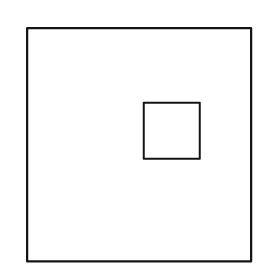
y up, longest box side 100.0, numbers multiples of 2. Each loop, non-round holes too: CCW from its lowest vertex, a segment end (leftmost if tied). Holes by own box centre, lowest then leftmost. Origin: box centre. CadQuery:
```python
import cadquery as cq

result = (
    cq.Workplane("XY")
    .moveTo(-48.0, -50.0)
    .lineTo(48.0, -50.0)
    .lineTo(48.0, 50.0)
    .lineTo(-48.0, 50.0)
    .close()
    .moveTo(2.0, -6.0)
    .lineTo(26.0, -6.0)
    .lineTo(26.0, 18.0)
    .lineTo(2.0, 18.0)
    .close()
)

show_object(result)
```